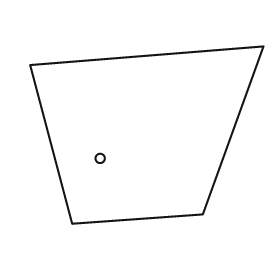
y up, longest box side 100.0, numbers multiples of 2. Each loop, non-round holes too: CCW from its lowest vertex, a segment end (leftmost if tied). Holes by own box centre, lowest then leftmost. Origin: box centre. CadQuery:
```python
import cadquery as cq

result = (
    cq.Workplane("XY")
    .moveTo(-32.0, -38.0)
    .lineTo(24.0, -34.0)
    .lineTo(50.0, 38.0)
    .lineTo(-50.0, 30.0)
    .close()
    .moveTo(-20.0, -10.0)
    .circle(2.0)
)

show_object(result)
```